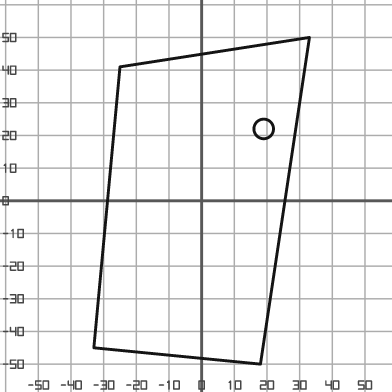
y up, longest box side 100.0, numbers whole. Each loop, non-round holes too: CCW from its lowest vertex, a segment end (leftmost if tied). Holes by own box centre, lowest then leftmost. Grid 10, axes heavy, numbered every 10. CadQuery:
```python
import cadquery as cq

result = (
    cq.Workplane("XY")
    .moveTo(18.0, -50.0)
    .lineTo(33.0, 50.0)
    .lineTo(-25.0, 41.0)
    .lineTo(-33.0, -45.0)
    .close()
    .moveTo(19.0, 22.0)
    .circle(3.0)
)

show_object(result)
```